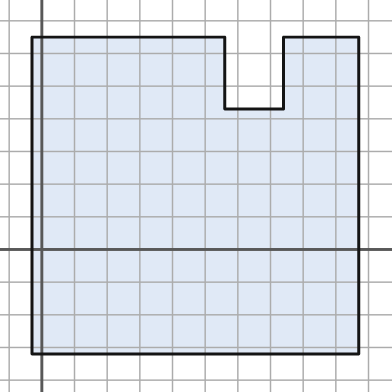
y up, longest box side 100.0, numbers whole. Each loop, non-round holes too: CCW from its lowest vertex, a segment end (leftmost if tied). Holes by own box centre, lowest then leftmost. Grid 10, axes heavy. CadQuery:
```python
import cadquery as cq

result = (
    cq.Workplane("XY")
    .moveTo(-3.0, -32.0)
    .lineTo(97.0, -32.0)
    .lineTo(97.0, 65.0)
    .lineTo(74.0, 65.0)
    .lineTo(74.0, 43.0)
    .lineTo(56.0, 43.0)
    .lineTo(56.0, 65.0)
    .lineTo(-3.0, 65.0)
    .close()
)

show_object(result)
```